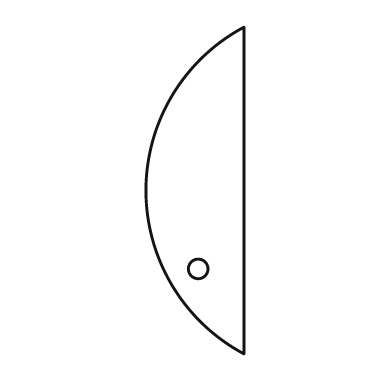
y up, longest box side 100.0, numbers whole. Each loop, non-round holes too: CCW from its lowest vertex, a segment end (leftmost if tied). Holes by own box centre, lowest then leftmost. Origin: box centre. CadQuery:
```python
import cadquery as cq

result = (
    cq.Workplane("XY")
    .moveTo(15.0, -50.0)
    .lineTo(15.0, 50.0)
    .threePointArc((-15.0, 0.0), (15.0, -50.0))
    .close()
    .moveTo(1.0, -24.0)
    .circle(3.0)
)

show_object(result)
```